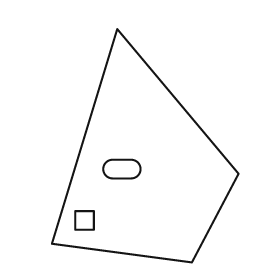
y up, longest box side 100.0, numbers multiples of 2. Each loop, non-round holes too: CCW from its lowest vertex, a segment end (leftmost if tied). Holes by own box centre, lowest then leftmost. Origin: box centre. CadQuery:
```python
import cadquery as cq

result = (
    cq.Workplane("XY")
    .moveTo(20.0, -50.0)
    .lineTo(40.0, -12.0)
    .lineTo(-12.0, 50.0)
    .lineTo(-40.0, -42.0)
    .close()
    .moveTo(-30.0, -36.0)
    .lineTo(-22.0, -36.0)
    .lineTo(-22.0, -28.0)
    .lineTo(-30.0, -28.0)
    .close()
    .moveTo(-14.0, -14.0)
    .lineTo(-6.0, -14.0)
    .threePointArc((-2.0, -10.0), (-6.0, -6.0))
    .lineTo(-14.0, -6.0)
    .threePointArc((-18.0, -10.0), (-14.0, -14.0))
    .close()
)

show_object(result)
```